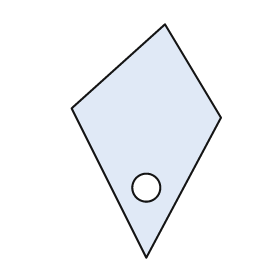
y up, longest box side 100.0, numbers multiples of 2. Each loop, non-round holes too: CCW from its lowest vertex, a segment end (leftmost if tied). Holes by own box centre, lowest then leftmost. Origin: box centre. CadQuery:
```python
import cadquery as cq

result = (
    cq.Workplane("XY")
    .moveTo(0.0, -50.0)
    .lineTo(32.0, 10.0)
    .lineTo(8.0, 50.0)
    .lineTo(-32.0, 14.0)
    .close()
    .moveTo(0.0, -20.0)
    .circle(6.0)
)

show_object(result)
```